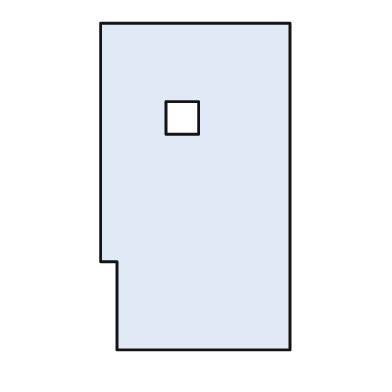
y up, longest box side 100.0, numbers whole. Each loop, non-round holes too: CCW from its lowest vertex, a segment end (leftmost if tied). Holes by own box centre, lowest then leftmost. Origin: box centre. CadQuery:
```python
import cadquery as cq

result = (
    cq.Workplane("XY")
    .moveTo(-24.0, -50.0)
    .lineTo(29.0, -50.0)
    .lineTo(29.0, 50.0)
    .lineTo(-29.0, 50.0)
    .lineTo(-29.0, -23.0)
    .lineTo(-24.0, -23.0)
    .close()
    .moveTo(-9.0, 16.0)
    .lineTo(1.0, 16.0)
    .lineTo(1.0, 26.0)
    .lineTo(-9.0, 26.0)
    .close()
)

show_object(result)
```